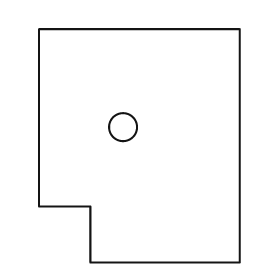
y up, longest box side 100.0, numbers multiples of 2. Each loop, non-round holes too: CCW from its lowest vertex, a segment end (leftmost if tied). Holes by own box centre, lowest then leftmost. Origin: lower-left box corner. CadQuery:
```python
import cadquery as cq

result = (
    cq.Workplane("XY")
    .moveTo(22.0, 0.0)
    .lineTo(86.0, 0.0)
    .lineTo(86.0, 100.0)
    .lineTo(0.0, 100.0)
    .lineTo(0.0, 24.0)
    .lineTo(22.0, 24.0)
    .close()
    .moveTo(36.0, 58.0)
    .circle(6.0)
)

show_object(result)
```